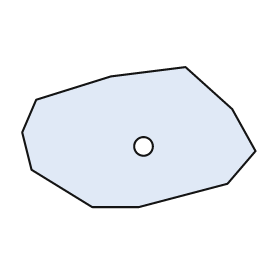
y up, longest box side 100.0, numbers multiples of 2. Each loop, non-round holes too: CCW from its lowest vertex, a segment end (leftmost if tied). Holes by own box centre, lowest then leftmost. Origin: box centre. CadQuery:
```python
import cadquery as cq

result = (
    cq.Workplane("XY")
    .moveTo(-20.0, -30.0)
    .lineTo(0.0, -30.0)
    .lineTo(38.0, -20.0)
    .lineTo(50.0, -6.0)
    .lineTo(40.0, 12.0)
    .lineTo(20.0, 30.0)
    .lineTo(-12.0, 26.0)
    .lineTo(-44.0, 16.0)
    .lineTo(-50.0, 2.0)
    .lineTo(-46.0, -14.0)
    .close()
    .moveTo(2.0, -4.0)
    .circle(4.0)
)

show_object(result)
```